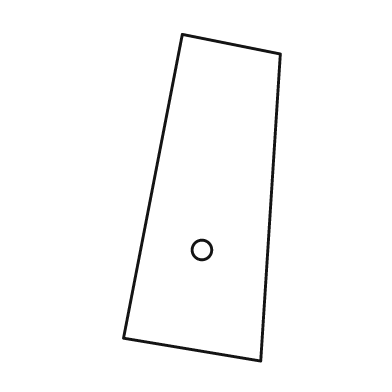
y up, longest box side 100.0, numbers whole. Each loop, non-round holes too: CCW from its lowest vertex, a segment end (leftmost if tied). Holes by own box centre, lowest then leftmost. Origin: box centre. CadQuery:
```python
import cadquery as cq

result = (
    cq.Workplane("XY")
    .moveTo(18.0, -50.0)
    .lineTo(24.0, 44.0)
    .lineTo(-6.0, 50.0)
    .lineTo(-24.0, -43.0)
    .close()
    .moveTo(0.0, -16.0)
    .circle(3.0)
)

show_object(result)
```